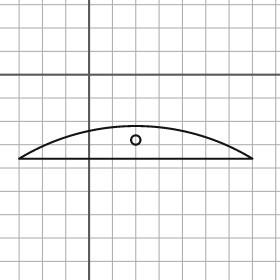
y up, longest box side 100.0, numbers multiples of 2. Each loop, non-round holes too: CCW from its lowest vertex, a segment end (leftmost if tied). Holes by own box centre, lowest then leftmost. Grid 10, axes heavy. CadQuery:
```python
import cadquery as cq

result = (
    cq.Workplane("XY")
    .moveTo(-30.0, -36.0)
    .lineTo(70.0, -36.0)
    .threePointArc((20.0, -22.0), (-30.0, -36.0))
    .close()
    .moveTo(20.0, -28.0)
    .circle(2.0)
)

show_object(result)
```